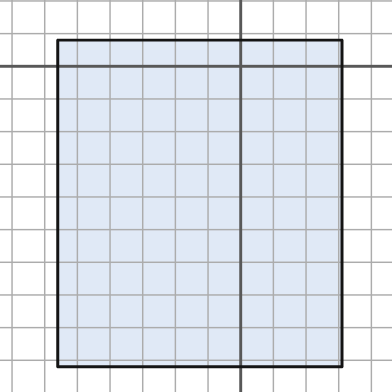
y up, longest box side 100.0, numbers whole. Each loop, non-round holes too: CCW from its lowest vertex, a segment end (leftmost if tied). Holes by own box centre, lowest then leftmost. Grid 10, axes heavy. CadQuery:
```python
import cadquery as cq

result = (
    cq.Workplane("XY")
    .moveTo(-56.0, -92.0)
    .lineTo(31.0, -92.0)
    .lineTo(31.0, 8.0)
    .lineTo(-56.0, 8.0)
    .close()
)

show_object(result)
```